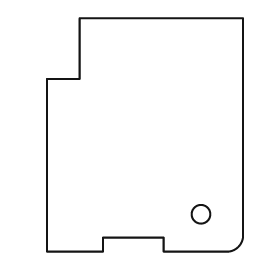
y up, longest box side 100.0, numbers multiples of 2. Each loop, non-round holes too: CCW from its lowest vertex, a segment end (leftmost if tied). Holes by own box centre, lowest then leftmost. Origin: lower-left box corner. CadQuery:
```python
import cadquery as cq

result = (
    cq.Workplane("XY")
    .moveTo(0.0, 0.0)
    .lineTo(24.0, 0.0)
    .lineTo(24.0, 6.0)
    .lineTo(50.0, 6.0)
    .lineTo(50.0, 0.0)
    .lineTo(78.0, 0.0)
    .threePointArc((82.0, 2.0), (84.0, 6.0))
    .lineTo(84.0, 100.0)
    .lineTo(14.0, 100.0)
    .lineTo(14.0, 74.0)
    .lineTo(0.0, 74.0)
    .close()
    .moveTo(66.0, 16.0)
    .circle(4.0)
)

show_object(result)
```